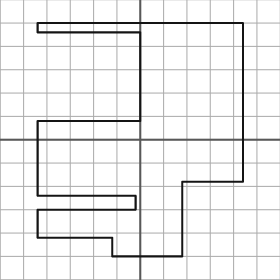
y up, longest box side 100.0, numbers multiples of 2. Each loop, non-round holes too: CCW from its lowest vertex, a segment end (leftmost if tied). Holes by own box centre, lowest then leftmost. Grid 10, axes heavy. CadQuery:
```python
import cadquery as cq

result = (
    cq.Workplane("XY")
    .moveTo(-12.0, -50.0)
    .lineTo(18.0, -50.0)
    .lineTo(18.0, -18.0)
    .lineTo(44.0, -18.0)
    .lineTo(44.0, 50.0)
    .lineTo(-44.0, 50.0)
    .lineTo(-44.0, 46.0)
    .lineTo(0.0, 46.0)
    .lineTo(0.0, 8.0)
    .lineTo(-44.0, 8.0)
    .lineTo(-44.0, -24.0)
    .lineTo(-2.0, -24.0)
    .lineTo(-2.0, -30.0)
    .lineTo(-44.0, -30.0)
    .lineTo(-44.0, -42.0)
    .lineTo(-12.0, -42.0)
    .close()
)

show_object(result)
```